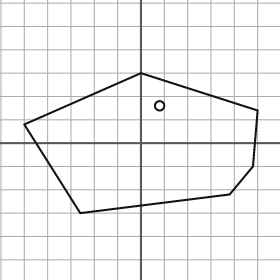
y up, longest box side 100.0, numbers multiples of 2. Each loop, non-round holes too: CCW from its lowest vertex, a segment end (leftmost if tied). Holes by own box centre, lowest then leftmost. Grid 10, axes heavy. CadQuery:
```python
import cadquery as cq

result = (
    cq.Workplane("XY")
    .moveTo(-26.0, -30.0)
    .lineTo(38.0, -22.0)
    .lineTo(48.0, -10.0)
    .lineTo(50.0, 14.0)
    .lineTo(0.0, 30.0)
    .lineTo(-50.0, 8.0)
    .close()
    .moveTo(8.0, 16.0)
    .circle(2.0)
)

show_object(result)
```